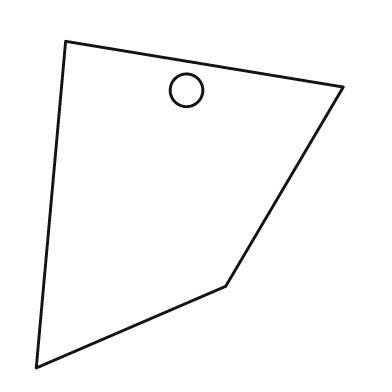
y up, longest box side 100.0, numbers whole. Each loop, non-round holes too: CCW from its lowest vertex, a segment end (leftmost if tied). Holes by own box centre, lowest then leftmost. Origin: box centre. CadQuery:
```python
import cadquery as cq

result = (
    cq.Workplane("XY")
    .moveTo(-47.0, -50.0)
    .lineTo(11.0, -25.0)
    .lineTo(47.0, 36.0)
    .lineTo(-38.0, 50.0)
    .close()
    .moveTo(-1.0, 35.0)
    .circle(5.0)
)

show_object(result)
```